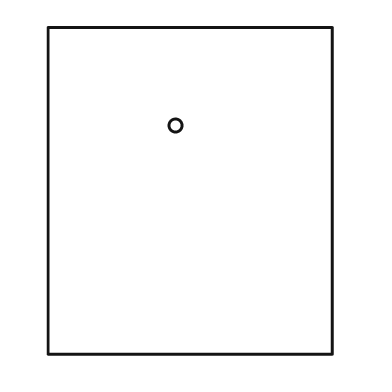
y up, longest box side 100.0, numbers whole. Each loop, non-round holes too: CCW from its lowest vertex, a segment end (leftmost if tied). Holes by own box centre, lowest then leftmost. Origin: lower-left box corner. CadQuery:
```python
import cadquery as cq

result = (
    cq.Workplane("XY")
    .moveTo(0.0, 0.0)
    .lineTo(87.0, 0.0)
    .lineTo(87.0, 100.0)
    .lineTo(0.0, 100.0)
    .close()
    .moveTo(39.0, 70.0)
    .circle(2.0)
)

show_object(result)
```